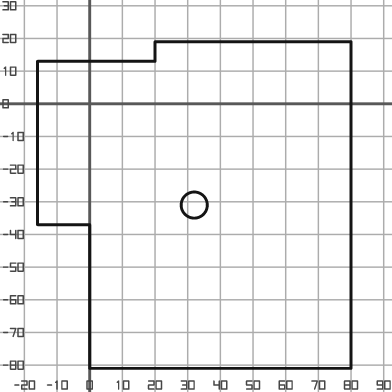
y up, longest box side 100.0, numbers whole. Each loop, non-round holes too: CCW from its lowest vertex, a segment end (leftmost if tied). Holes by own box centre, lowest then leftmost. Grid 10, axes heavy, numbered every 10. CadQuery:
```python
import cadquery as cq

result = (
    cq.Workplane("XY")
    .moveTo(0.0, -81.0)
    .lineTo(80.0, -81.0)
    .lineTo(80.0, 19.0)
    .lineTo(20.0, 19.0)
    .lineTo(20.0, 13.0)
    .lineTo(-16.0, 13.0)
    .lineTo(-16.0, -37.0)
    .lineTo(0.0, -37.0)
    .close()
    .moveTo(32.0, -31.0)
    .circle(4.0)
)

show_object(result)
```